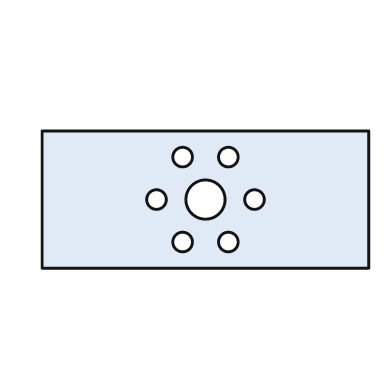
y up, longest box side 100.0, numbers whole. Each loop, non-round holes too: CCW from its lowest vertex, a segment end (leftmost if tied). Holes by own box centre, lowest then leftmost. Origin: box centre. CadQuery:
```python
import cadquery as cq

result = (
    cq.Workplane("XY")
    .moveTo(-50.0, -21.0)
    .lineTo(50.0, -21.0)
    .lineTo(50.0, 21.0)
    .lineTo(-50.0, 21.0)
    .close()
    .moveTo(-7.0, -13.0)
    .circle(3.0)
    .moveTo(7.0, -13.0)
    .circle(3.0)
    .moveTo(-15.0, 0.0)
    .circle(3.0)
    .moveTo(0.0, 0.0)
    .circle(6.0)
    .moveTo(15.0, 0.0)
    .circle(3.0)
    .moveTo(-7.0, 13.0)
    .circle(3.0)
    .moveTo(7.0, 13.0)
    .circle(3.0)
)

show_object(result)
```